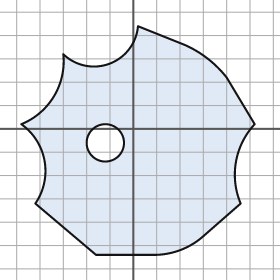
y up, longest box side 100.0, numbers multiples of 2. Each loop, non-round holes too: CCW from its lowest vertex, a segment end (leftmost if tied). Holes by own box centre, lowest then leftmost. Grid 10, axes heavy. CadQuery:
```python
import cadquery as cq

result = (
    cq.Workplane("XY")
    .moveTo(-16.0, -54.0)
    .lineTo(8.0, -54.0)
    .threePointArc((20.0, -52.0), (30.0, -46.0))
    .lineTo(46.0, -32.0)
    .threePointArc((44.0, -14.0), (52.0, 2.0))
    .lineTo(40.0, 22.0)
    .threePointArc((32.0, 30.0), (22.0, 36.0))
    .lineTo(2.0, 44.0)
    .threePointArc((-10.0, 28.0), (-30.0, 32.0))
    .threePointArc((-34.0, 14.0), (-48.0, 2.0))
    .threePointArc((-38.0, -14.0), (-42.0, -32.0))
    .close()
    .moveTo(-12.0, -6.0)
    .circle(8.0)
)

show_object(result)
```